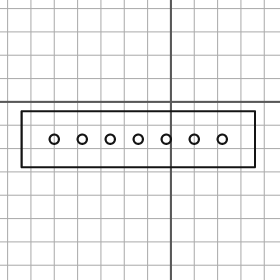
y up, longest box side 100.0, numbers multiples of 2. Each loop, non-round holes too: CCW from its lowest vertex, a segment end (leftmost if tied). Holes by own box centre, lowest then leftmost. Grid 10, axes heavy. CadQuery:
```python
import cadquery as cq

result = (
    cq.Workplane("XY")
    .moveTo(-64.0, -28.0)
    .lineTo(36.0, -28.0)
    .lineTo(36.0, -4.0)
    .lineTo(-64.0, -4.0)
    .close()
    .moveTo(-50.0, -16.0)
    .circle(2.0)
    .moveTo(-38.0, -16.0)
    .circle(2.0)
    .moveTo(-26.0, -16.0)
    .circle(2.0)
    .moveTo(-14.0, -16.0)
    .circle(2.0)
    .moveTo(-2.0, -16.0)
    .circle(2.0)
    .moveTo(10.0, -16.0)
    .circle(2.0)
    .moveTo(22.0, -16.0)
    .circle(2.0)
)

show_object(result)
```